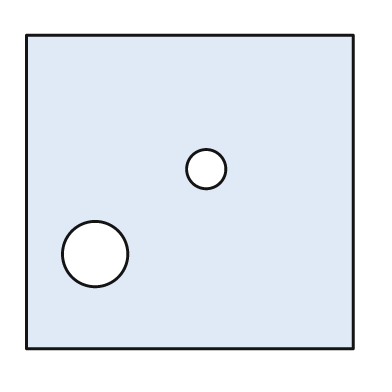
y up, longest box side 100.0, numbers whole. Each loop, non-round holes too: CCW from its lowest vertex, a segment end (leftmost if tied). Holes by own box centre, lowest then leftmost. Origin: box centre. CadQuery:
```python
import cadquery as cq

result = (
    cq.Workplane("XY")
    .moveTo(-50.0, -48.0)
    .lineTo(50.0, -48.0)
    .lineTo(50.0, 48.0)
    .lineTo(-50.0, 48.0)
    .close()
    .moveTo(-29.0, -19.0)
    .circle(10.0)
    .moveTo(5.0, 7.0)
    .circle(6.0)
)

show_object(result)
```